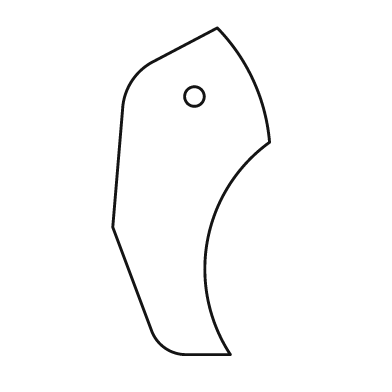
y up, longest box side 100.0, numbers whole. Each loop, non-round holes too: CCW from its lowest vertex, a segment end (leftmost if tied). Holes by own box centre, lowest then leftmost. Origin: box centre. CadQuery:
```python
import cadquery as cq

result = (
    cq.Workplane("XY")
    .moveTo(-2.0, -50.0)
    .lineTo(12.0, -50.0)
    .threePointArc((5.0, -15.0), (24.0, 15.0))
    .threePointArc((19.0, 34.0), (8.0, 50.0))
    .lineTo(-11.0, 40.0)
    .threePointArc((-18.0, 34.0), (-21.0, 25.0))
    .lineTo(-24.0, -11.0)
    .lineTo(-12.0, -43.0)
    .threePointArc((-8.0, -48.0), (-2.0, -50.0))
    .close()
    .moveTo(1.0, 29.0)
    .circle(3.0)
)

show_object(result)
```